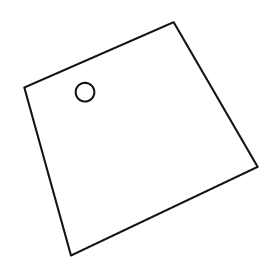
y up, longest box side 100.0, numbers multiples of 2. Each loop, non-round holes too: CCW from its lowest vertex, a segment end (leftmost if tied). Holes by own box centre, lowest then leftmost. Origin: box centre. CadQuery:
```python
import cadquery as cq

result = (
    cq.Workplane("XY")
    .moveTo(-30.0, -50.0)
    .lineTo(50.0, -12.0)
    .lineTo(14.0, 50.0)
    .lineTo(-50.0, 22.0)
    .close()
    .moveTo(-24.0, 20.0)
    .circle(4.0)
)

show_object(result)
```